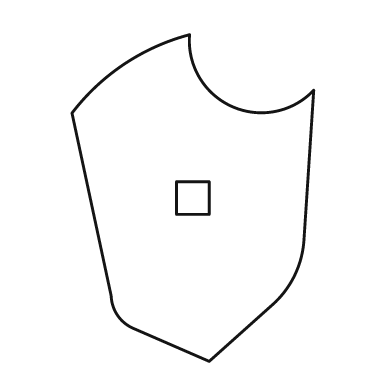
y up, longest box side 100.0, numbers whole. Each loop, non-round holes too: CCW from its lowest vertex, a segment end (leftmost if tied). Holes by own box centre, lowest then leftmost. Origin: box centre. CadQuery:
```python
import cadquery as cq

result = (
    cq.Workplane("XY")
    .moveTo(5.0, -50.0)
    .lineTo(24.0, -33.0)
    .threePointArc((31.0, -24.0), (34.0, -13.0))
    .lineTo(37.0, 33.0)
    .threePointArc((12.0, 28.0), (-1.0, 50.0))
    .threePointArc((-21.0, 41.0), (-37.0, 26.0))
    .lineTo(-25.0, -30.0)
    .threePointArc((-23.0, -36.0), (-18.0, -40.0))
    .close()
    .moveTo(-5.0, -5.0)
    .lineTo(5.0, -5.0)
    .lineTo(5.0, 5.0)
    .lineTo(-5.0, 5.0)
    .close()
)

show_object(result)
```